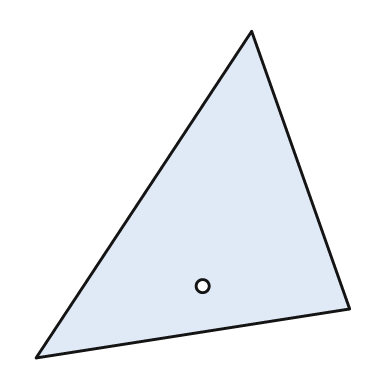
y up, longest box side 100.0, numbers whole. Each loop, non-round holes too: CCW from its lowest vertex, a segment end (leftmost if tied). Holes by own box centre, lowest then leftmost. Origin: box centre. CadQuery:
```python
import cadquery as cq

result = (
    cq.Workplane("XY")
    .moveTo(-48.0, -50.0)
    .lineTo(48.0, -35.0)
    .lineTo(18.0, 50.0)
    .close()
    .moveTo(3.0, -28.0)
    .circle(2.0)
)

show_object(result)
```